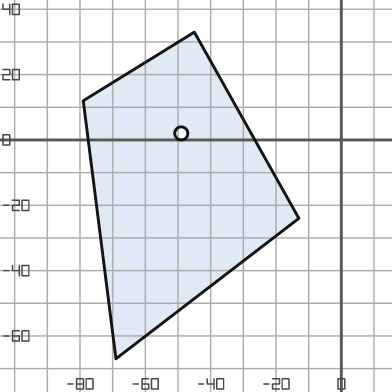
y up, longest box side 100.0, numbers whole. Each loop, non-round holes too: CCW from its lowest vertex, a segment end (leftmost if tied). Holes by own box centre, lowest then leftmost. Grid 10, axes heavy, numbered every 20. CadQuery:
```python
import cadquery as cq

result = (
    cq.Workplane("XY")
    .moveTo(-69.0, -67.0)
    .lineTo(-13.0, -24.0)
    .lineTo(-45.0, 33.0)
    .lineTo(-79.0, 12.0)
    .close()
    .moveTo(-49.0, 2.0)
    .circle(2.0)
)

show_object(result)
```